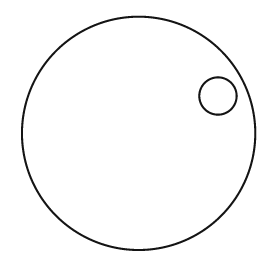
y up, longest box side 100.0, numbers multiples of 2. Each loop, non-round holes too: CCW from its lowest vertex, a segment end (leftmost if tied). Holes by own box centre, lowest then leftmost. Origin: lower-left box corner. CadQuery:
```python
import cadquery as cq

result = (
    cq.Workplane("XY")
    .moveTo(50.0, 50.0)
    .circle(50.0)
    .moveTo(84.0, 66.0)
    .circle(8.0)
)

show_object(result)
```